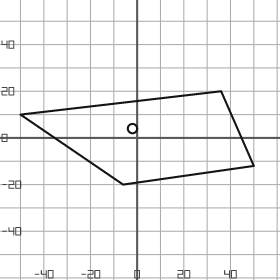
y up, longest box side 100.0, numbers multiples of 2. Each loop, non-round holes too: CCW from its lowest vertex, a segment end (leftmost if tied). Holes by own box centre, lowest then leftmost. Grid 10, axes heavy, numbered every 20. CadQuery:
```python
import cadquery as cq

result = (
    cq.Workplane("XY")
    .moveTo(-6.0, -20.0)
    .lineTo(50.0, -12.0)
    .lineTo(36.0, 20.0)
    .lineTo(-50.0, 10.0)
    .close()
    .moveTo(-2.0, 4.0)
    .circle(2.0)
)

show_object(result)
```